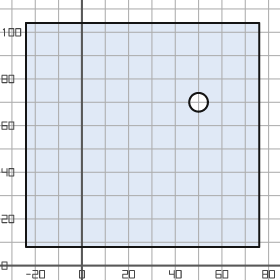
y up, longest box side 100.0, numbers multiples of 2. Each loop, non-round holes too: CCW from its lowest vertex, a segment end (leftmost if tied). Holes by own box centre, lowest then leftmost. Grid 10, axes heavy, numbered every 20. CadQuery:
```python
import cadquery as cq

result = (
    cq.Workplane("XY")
    .moveTo(-24.0, 8.0)
    .lineTo(76.0, 8.0)
    .lineTo(76.0, 104.0)
    .lineTo(-24.0, 104.0)
    .close()
    .moveTo(50.0, 70.0)
    .circle(4.0)
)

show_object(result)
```